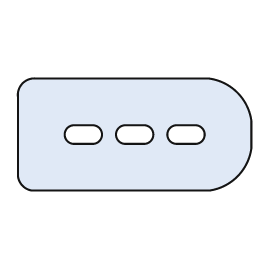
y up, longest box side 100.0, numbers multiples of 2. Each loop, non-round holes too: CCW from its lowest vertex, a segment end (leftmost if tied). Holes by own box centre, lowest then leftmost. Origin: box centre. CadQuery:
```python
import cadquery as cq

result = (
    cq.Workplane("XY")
    .moveTo(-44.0, -24.0)
    .lineTo(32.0, -24.0)
    .threePointArc((44.0, -18.0), (50.0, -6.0))
    .lineTo(50.0, 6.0)
    .threePointArc((44.0, 18.0), (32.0, 24.0))
    .lineTo(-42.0, 24.0)
    .threePointArc((-48.0, 22.0), (-50.0, 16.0))
    .lineTo(-50.0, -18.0)
    .threePointArc((-48.0, -22.0), (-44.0, -24.0))
    .close()
    .moveTo(-26.0, -4.0)
    .lineTo(-18.0, -4.0)
    .threePointArc((-14.0, 0.0), (-18.0, 4.0))
    .lineTo(-26.0, 4.0)
    .threePointArc((-30.0, 0.0), (-26.0, -4.0))
    .close()
    .moveTo(-4.0, -4.0)
    .lineTo(4.0, -4.0)
    .threePointArc((8.0, 0.0), (4.0, 4.0))
    .lineTo(-4.0, 4.0)
    .threePointArc((-8.0, 0.0), (-4.0, -4.0))
    .close()
    .moveTo(18.0, -4.0)
    .lineTo(26.0, -4.0)
    .threePointArc((30.0, 0.0), (26.0, 4.0))
    .lineTo(18.0, 4.0)
    .threePointArc((14.0, 0.0), (18.0, -4.0))
    .close()
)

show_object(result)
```